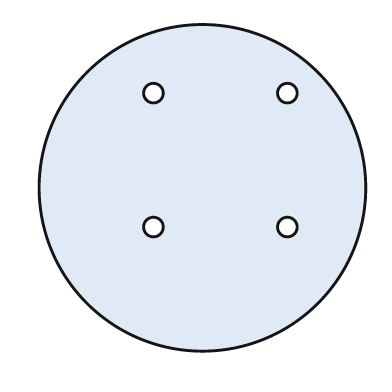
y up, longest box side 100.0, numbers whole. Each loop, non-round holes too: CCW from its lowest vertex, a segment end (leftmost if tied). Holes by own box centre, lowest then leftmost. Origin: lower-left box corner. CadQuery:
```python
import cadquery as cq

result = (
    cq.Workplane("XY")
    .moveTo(50.0, 50.0)
    .circle(50.0)
    .moveTo(35.0, 38.0)
    .circle(3.0)
    .moveTo(76.0, 38.0)
    .circle(3.0)
    .moveTo(35.0, 79.0)
    .circle(3.0)
    .moveTo(76.0, 79.0)
    .circle(3.0)
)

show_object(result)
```